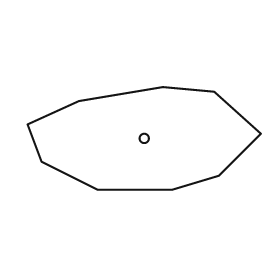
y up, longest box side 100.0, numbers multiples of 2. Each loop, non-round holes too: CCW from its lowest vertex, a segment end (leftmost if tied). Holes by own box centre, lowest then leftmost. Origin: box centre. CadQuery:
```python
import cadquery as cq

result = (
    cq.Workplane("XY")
    .moveTo(-20.0, -22.0)
    .lineTo(12.0, -22.0)
    .lineTo(32.0, -16.0)
    .lineTo(50.0, 2.0)
    .lineTo(30.0, 20.0)
    .lineTo(8.0, 22.0)
    .lineTo(-28.0, 16.0)
    .lineTo(-50.0, 6.0)
    .lineTo(-44.0, -10.0)
    .close()
    .moveTo(0.0, 0.0)
    .circle(2.0)
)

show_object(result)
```